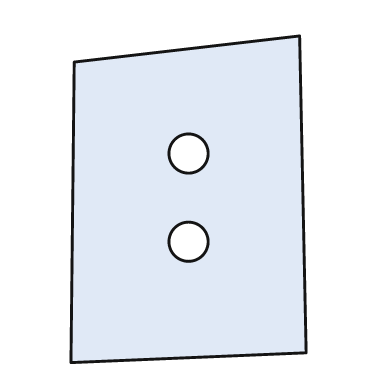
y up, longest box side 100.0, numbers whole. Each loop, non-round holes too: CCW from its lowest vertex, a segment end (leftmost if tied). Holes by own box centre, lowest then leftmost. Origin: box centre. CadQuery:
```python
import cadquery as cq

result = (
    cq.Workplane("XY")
    .moveTo(-36.0, -50.0)
    .lineTo(36.0, -47.0)
    .lineTo(34.0, 50.0)
    .lineTo(-35.0, 42.0)
    .close()
    .moveTo(0.0, -13.0)
    .circle(6.0)
    .moveTo(0.0, 14.0)
    .circle(6.0)
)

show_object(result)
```